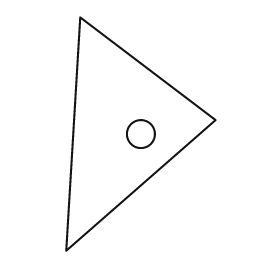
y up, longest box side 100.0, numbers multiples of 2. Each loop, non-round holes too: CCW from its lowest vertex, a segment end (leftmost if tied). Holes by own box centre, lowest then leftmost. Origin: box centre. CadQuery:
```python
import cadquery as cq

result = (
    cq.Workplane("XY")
    .moveTo(-32.0, -50.0)
    .lineTo(32.0, 6.0)
    .lineTo(-26.0, 50.0)
    .close()
    .moveTo(0.0, 0.0)
    .circle(6.0)
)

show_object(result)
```